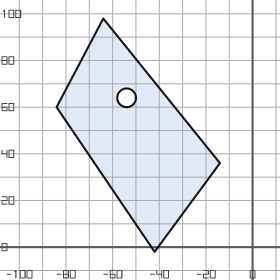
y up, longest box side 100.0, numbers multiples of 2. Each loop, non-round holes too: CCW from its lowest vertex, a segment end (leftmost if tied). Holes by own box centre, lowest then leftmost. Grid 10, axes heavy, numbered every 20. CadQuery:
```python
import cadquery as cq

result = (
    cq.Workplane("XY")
    .moveTo(-42.0, -2.0)
    .lineTo(-14.0, 36.0)
    .lineTo(-64.0, 98.0)
    .lineTo(-84.0, 60.0)
    .close()
    .moveTo(-54.0, 64.0)
    .circle(4.0)
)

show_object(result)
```